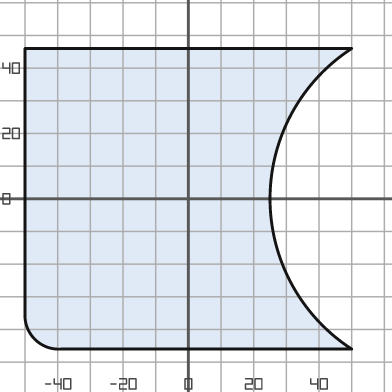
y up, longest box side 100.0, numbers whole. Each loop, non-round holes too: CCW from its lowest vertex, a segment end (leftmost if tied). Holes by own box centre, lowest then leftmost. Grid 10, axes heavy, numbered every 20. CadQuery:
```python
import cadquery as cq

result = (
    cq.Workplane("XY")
    .moveTo(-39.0, -46.0)
    .lineTo(50.0, -46.0)
    .threePointArc((25.0, 0.0), (50.0, 46.0))
    .lineTo(-50.0, 46.0)
    .lineTo(-50.0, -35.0)
    .threePointArc((-47.0, -43.0), (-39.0, -46.0))
    .close()
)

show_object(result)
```